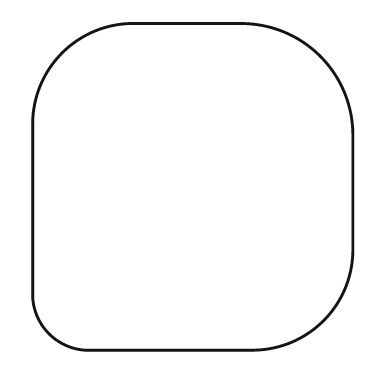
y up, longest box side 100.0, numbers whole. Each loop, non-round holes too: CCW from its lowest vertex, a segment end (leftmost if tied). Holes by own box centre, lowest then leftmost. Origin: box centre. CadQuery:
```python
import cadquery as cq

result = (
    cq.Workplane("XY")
    .moveTo(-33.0, -50.0)
    .lineTo(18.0, -50.0)
    .threePointArc((40.0, -41.0), (49.0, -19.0))
    .lineTo(49.0, 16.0)
    .threePointArc((39.0, 40.0), (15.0, 50.0))
    .lineTo(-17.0, 50.0)
    .threePointArc((-40.0, 41.0), (-49.0, 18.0))
    .lineTo(-49.0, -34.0)
    .threePointArc((-44.0, -45.0), (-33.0, -50.0))
    .close()
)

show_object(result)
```